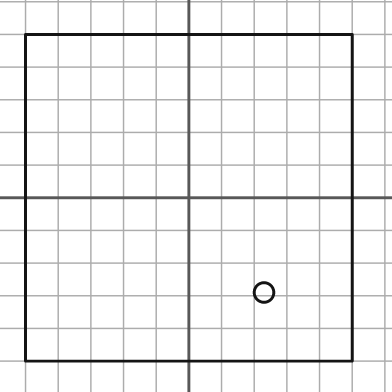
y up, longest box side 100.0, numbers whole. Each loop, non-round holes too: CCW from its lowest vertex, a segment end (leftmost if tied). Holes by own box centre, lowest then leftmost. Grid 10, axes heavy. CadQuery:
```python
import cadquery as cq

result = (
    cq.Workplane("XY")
    .moveTo(-50.0, -50.0)
    .lineTo(50.0, -50.0)
    .lineTo(50.0, 50.0)
    .lineTo(-50.0, 50.0)
    .close()
    .moveTo(23.0, -29.0)
    .circle(3.0)
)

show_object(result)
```